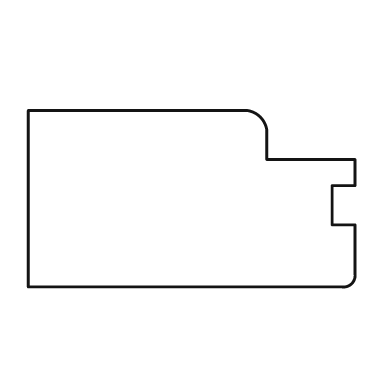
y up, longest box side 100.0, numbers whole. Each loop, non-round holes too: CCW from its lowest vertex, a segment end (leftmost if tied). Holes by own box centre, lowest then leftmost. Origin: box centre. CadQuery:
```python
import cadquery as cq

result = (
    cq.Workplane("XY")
    .moveTo(-50.0, -27.0)
    .lineTo(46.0, -27.0)
    .threePointArc((49.0, -26.0), (50.0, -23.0))
    .lineTo(50.0, -8.0)
    .lineTo(43.0, -8.0)
    .lineTo(43.0, 4.0)
    .lineTo(50.0, 4.0)
    .lineTo(50.0, 12.0)
    .lineTo(23.0, 12.0)
    .lineTo(23.0, 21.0)
    .threePointArc((21.0, 25.0), (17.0, 27.0))
    .lineTo(-50.0, 27.0)
    .close()
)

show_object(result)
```